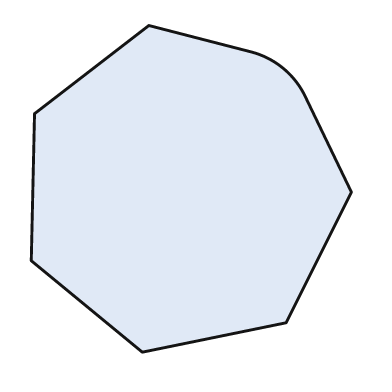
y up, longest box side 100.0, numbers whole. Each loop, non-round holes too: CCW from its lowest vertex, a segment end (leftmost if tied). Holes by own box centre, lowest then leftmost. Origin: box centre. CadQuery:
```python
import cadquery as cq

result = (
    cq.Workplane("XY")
    .moveTo(-15.0, -50.0)
    .lineTo(29.0, -41.0)
    .lineTo(49.0, -1.0)
    .lineTo(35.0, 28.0)
    .threePointArc((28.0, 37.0), (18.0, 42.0))
    .lineTo(-13.0, 50.0)
    .lineTo(-48.0, 23.0)
    .lineTo(-49.0, -22.0)
    .close()
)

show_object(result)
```